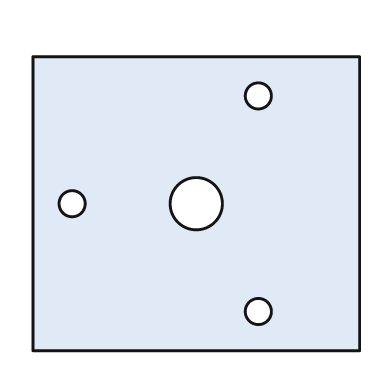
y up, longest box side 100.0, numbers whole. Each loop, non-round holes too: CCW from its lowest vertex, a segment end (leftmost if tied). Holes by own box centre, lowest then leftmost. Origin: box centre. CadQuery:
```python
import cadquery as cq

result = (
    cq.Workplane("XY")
    .moveTo(-50.0, -45.0)
    .lineTo(50.0, -45.0)
    .lineTo(50.0, 45.0)
    .lineTo(-50.0, 45.0)
    .close()
    .moveTo(19.0, -33.0)
    .circle(4.0)
    .moveTo(-38.0, 0.0)
    .circle(4.0)
    .moveTo(0.0, 0.0)
    .circle(8.0)
    .moveTo(19.0, 33.0)
    .circle(4.0)
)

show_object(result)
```